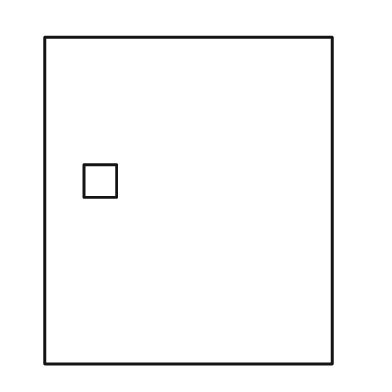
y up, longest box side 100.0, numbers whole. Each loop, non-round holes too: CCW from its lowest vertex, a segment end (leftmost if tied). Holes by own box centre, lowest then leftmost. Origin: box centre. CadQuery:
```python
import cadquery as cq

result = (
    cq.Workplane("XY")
    .moveTo(-44.0, -50.0)
    .lineTo(44.0, -50.0)
    .lineTo(44.0, 50.0)
    .lineTo(-44.0, 50.0)
    .close()
    .moveTo(-32.0, 1.0)
    .lineTo(-22.0, 1.0)
    .lineTo(-22.0, 11.0)
    .lineTo(-32.0, 11.0)
    .close()
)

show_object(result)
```